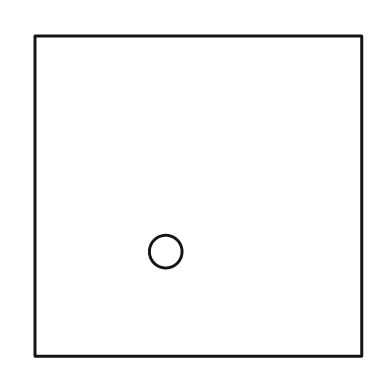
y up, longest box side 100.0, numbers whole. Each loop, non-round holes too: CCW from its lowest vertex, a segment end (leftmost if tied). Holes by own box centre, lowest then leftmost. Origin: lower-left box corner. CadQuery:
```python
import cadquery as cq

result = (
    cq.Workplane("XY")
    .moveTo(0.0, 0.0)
    .lineTo(100.0, 0.0)
    .lineTo(100.0, 98.0)
    .lineTo(0.0, 98.0)
    .close()
    .moveTo(40.0, 32.0)
    .circle(5.0)
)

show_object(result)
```